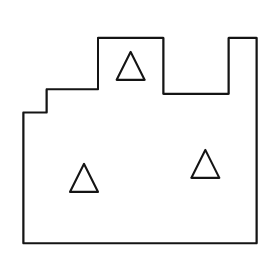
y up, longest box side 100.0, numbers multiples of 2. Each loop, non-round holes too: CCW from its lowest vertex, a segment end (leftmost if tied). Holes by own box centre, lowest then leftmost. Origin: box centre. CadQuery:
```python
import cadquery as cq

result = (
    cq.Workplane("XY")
    .moveTo(-50.0, -44.0)
    .lineTo(50.0, -44.0)
    .lineTo(50.0, 44.0)
    .lineTo(38.0, 44.0)
    .lineTo(38.0, 20.0)
    .lineTo(10.0, 20.0)
    .lineTo(10.0, 44.0)
    .lineTo(-18.0, 44.0)
    .lineTo(-18.0, 22.0)
    .lineTo(-40.0, 22.0)
    .lineTo(-40.0, 12.0)
    .lineTo(-50.0, 12.0)
    .close()
    .moveTo(-30.0, -22.0)
    .lineTo(-18.0, -22.0)
    .lineTo(-24.0, -10.0)
    .close()
    .moveTo(22.0, -16.0)
    .lineTo(34.0, -16.0)
    .lineTo(28.0, -4.0)
    .close()
    .moveTo(-10.0, 26.0)
    .lineTo(2.0, 26.0)
    .lineTo(-4.0, 38.0)
    .close()
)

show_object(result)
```